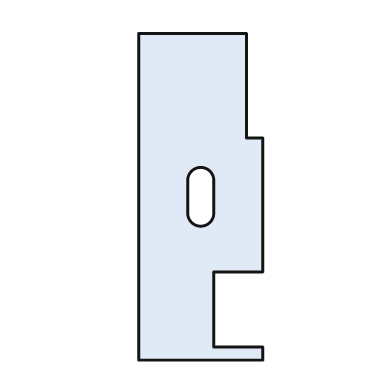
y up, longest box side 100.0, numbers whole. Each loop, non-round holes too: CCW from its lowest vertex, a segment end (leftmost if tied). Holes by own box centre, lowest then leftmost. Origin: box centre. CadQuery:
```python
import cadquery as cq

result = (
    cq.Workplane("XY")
    .moveTo(-19.0, -50.0)
    .lineTo(19.0, -50.0)
    .lineTo(19.0, -46.0)
    .lineTo(4.0, -46.0)
    .lineTo(4.0, -23.0)
    .lineTo(19.0, -23.0)
    .lineTo(19.0, 18.0)
    .lineTo(14.0, 18.0)
    .lineTo(14.0, 50.0)
    .lineTo(-19.0, 50.0)
    .close()
    .moveTo(-4.0, -5.0)
    .threePointArc((0.0, -9.0), (4.0, -5.0))
    .lineTo(4.0, 5.0)
    .threePointArc((0.0, 9.0), (-4.0, 5.0))
    .close()
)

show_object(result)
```